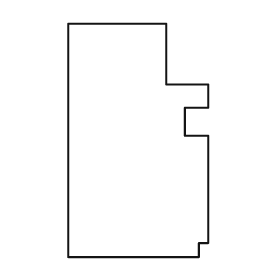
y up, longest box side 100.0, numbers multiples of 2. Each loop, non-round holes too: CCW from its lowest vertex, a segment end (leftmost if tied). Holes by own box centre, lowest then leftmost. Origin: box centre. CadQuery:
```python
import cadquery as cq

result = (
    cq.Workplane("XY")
    .moveTo(-30.0, -50.0)
    .lineTo(26.0, -50.0)
    .lineTo(26.0, -44.0)
    .lineTo(30.0, -44.0)
    .lineTo(30.0, 2.0)
    .lineTo(20.0, 2.0)
    .lineTo(20.0, 14.0)
    .lineTo(30.0, 14.0)
    .lineTo(30.0, 24.0)
    .lineTo(12.0, 24.0)
    .lineTo(12.0, 50.0)
    .lineTo(-30.0, 50.0)
    .close()
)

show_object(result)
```